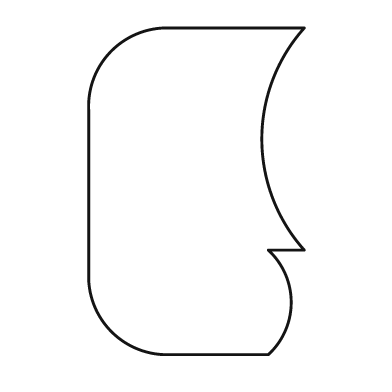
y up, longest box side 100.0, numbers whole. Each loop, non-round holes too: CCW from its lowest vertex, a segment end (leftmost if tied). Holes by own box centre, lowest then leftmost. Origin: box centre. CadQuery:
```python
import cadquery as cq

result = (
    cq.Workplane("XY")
    .moveTo(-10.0, -50.0)
    .lineTo(22.0, -50.0)
    .threePointArc((29.0, -34.0), (22.0, -18.0))
    .lineTo(33.0, -18.0)
    .threePointArc((20.0, 16.0), (33.0, 50.0))
    .lineTo(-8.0, 50.0)
    .threePointArc((-26.0, 43.0), (-33.0, 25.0))
    .lineTo(-33.0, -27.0)
    .threePointArc((-26.0, -43.0), (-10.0, -50.0))
    .close()
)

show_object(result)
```